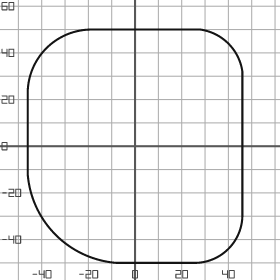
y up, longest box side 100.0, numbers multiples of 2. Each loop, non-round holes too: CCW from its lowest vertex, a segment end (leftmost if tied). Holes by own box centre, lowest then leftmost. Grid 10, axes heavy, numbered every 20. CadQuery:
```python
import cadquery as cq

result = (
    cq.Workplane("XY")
    .moveTo(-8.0, -50.0)
    .lineTo(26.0, -50.0)
    .threePointArc((40.0, -44.0), (46.0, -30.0))
    .lineTo(46.0, 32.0)
    .threePointArc((40.0, 44.0), (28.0, 50.0))
    .lineTo(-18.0, 50.0)
    .threePointArc((-38.0, 42.0), (-46.0, 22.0))
    .lineTo(-46.0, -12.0)
    .threePointArc((-34.0, -38.0), (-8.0, -50.0))
    .close()
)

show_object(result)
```